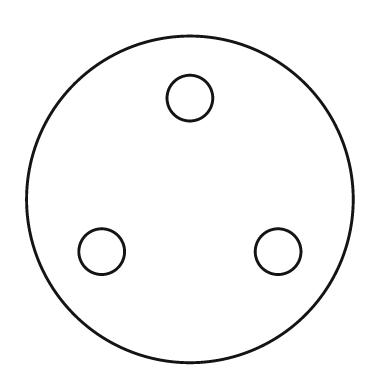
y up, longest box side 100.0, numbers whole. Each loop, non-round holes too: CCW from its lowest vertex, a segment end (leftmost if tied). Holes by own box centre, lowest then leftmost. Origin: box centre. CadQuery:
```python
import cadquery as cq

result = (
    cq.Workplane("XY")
    .moveTo(0.0, 0.0)
    .circle(50.0)
    .moveTo(-27.0, -16.0)
    .circle(7.0)
    .moveTo(27.0, -16.0)
    .circle(7.0)
    .moveTo(0.0, 31.0)
    .circle(7.0)
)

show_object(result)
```